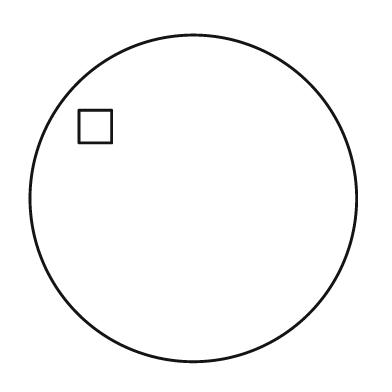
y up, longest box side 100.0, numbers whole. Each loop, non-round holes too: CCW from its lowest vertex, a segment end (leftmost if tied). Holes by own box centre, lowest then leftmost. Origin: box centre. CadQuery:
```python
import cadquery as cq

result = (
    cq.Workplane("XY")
    .moveTo(0.0, 0.0)
    .circle(50.0)
    .moveTo(-35.0, 17.0)
    .lineTo(-25.0, 17.0)
    .lineTo(-25.0, 27.0)
    .lineTo(-35.0, 27.0)
    .close()
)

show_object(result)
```